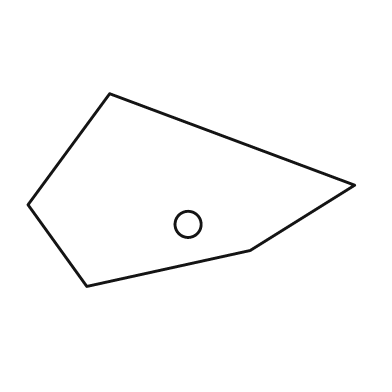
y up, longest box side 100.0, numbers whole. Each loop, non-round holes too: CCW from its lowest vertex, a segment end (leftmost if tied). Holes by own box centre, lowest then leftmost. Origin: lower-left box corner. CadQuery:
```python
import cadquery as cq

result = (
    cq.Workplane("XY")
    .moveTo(18.0, 0.0)
    .lineTo(68.0, 11.0)
    .lineTo(100.0, 31.0)
    .lineTo(25.0, 59.0)
    .lineTo(0.0, 25.0)
    .close()
    .moveTo(49.0, 19.0)
    .circle(4.0)
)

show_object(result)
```